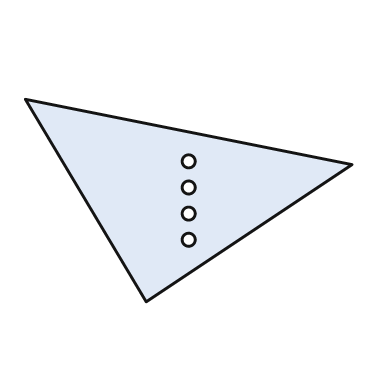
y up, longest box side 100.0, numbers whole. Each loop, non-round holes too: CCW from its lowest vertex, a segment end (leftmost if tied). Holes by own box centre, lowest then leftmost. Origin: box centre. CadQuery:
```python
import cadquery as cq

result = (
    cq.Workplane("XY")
    .moveTo(-13.0, -31.0)
    .lineTo(50.0, 11.0)
    .lineTo(-50.0, 31.0)
    .close()
    .moveTo(0.0, -12.0)
    .circle(2.0)
    .moveTo(0.0, -4.0)
    .circle(2.0)
    .moveTo(0.0, 4.0)
    .circle(2.0)
    .moveTo(0.0, 12.0)
    .circle(2.0)
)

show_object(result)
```